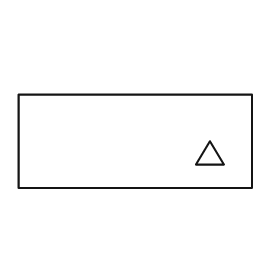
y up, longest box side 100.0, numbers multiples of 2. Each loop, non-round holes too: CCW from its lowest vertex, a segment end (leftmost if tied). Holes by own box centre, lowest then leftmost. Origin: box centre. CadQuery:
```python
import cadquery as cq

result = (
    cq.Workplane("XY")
    .moveTo(-50.0, -20.0)
    .lineTo(50.0, -20.0)
    .lineTo(50.0, 20.0)
    .lineTo(-50.0, 20.0)
    .close()
    .moveTo(26.0, -10.0)
    .lineTo(38.0, -10.0)
    .lineTo(32.0, 0.0)
    .close()
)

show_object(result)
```